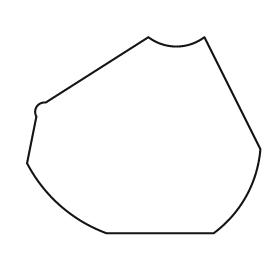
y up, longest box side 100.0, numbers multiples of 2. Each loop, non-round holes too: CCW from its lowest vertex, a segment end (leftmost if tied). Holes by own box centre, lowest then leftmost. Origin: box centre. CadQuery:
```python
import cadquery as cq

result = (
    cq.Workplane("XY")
    .moveTo(-16.0, -42.0)
    .lineTo(30.0, -42.0)
    .threePointArc((44.0, -26.0), (50.0, -6.0))
    .lineTo(26.0, 42.0)
    .threePointArc((14.0, 38.0), (2.0, 42.0))
    .lineTo(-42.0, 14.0)
    .threePointArc((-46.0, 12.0), (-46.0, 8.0))
    .lineTo(-50.0, -12.0)
    .threePointArc((-36.0, -30.0), (-16.0, -42.0))
    .close()
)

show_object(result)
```